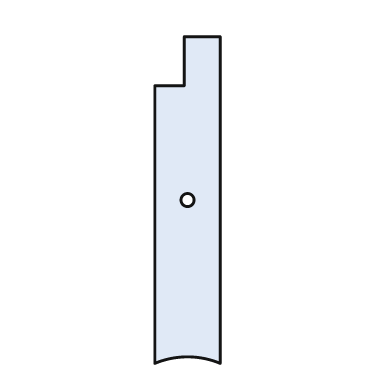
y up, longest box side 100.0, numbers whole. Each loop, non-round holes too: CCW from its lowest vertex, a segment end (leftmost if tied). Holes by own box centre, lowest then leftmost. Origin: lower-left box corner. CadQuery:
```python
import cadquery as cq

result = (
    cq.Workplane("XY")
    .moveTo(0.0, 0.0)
    .threePointArc((10.0, 2.0), (20.0, 0.0))
    .lineTo(20.0, 100.0)
    .lineTo(9.0, 100.0)
    .lineTo(9.0, 85.0)
    .lineTo(0.0, 85.0)
    .close()
    .moveTo(10.0, 50.0)
    .circle(2.0)
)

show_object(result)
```